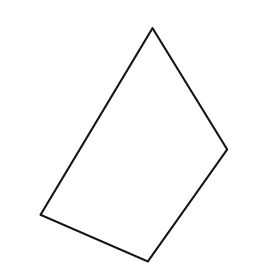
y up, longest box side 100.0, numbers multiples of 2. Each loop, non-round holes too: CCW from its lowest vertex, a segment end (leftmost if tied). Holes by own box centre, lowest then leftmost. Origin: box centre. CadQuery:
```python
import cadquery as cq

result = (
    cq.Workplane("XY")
    .moveTo(6.0, -50.0)
    .lineTo(40.0, -2.0)
    .lineTo(8.0, 50.0)
    .lineTo(-40.0, -30.0)
    .close()
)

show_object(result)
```